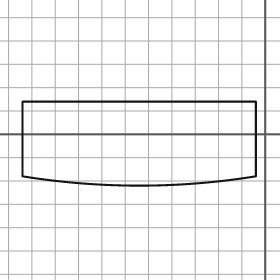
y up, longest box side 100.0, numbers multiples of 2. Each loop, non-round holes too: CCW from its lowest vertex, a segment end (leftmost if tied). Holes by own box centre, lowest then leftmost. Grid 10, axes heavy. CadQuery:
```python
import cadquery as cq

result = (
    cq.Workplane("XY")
    .moveTo(-104.0, -18.0)
    .threePointArc((-54.0, -22.0), (-4.0, -18.0))
    .lineTo(-4.0, 14.0)
    .lineTo(-104.0, 14.0)
    .close()
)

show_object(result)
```